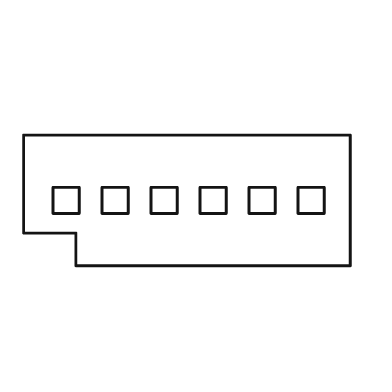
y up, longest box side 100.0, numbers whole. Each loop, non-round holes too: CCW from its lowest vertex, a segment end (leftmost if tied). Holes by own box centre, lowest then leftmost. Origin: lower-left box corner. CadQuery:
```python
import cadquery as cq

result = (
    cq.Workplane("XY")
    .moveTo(16.0, 0.0)
    .lineTo(100.0, 0.0)
    .lineTo(100.0, 40.0)
    .lineTo(0.0, 40.0)
    .lineTo(0.0, 10.0)
    .lineTo(16.0, 10.0)
    .close()
    .moveTo(9.0, 16.0)
    .lineTo(17.0, 16.0)
    .lineTo(17.0, 24.0)
    .lineTo(9.0, 24.0)
    .close()
    .moveTo(24.0, 16.0)
    .lineTo(32.0, 16.0)
    .lineTo(32.0, 24.0)
    .lineTo(24.0, 24.0)
    .close()
    .moveTo(39.0, 16.0)
    .lineTo(47.0, 16.0)
    .lineTo(47.0, 24.0)
    .lineTo(39.0, 24.0)
    .close()
    .moveTo(54.0, 16.0)
    .lineTo(62.0, 16.0)
    .lineTo(62.0, 24.0)
    .lineTo(54.0, 24.0)
    .close()
    .moveTo(69.0, 16.0)
    .lineTo(77.0, 16.0)
    .lineTo(77.0, 24.0)
    .lineTo(69.0, 24.0)
    .close()
    .moveTo(84.0, 16.0)
    .lineTo(92.0, 16.0)
    .lineTo(92.0, 24.0)
    .lineTo(84.0, 24.0)
    .close()
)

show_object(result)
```